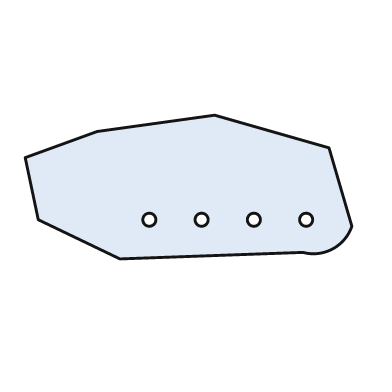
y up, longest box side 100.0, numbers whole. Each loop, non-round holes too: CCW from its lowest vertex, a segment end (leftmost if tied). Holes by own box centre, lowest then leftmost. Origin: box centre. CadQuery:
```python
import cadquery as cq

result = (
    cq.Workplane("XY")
    .moveTo(-21.0, -22.0)
    .lineTo(35.0, -20.0)
    .threePointArc((44.0, -19.0), (50.0, -12.0))
    .lineTo(43.0, 12.0)
    .lineTo(8.0, 22.0)
    .lineTo(-28.0, 17.0)
    .lineTo(-50.0, 9.0)
    .lineTo(-46.0, -10.0)
    .close()
    .moveTo(-12.0, -10.0)
    .circle(2.0)
    .moveTo(4.0, -10.0)
    .circle(2.0)
    .moveTo(20.0, -10.0)
    .circle(2.0)
    .moveTo(36.0, -10.0)
    .circle(2.0)
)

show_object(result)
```